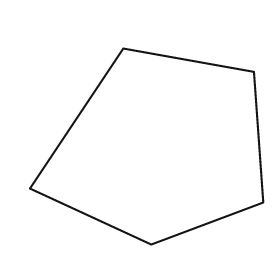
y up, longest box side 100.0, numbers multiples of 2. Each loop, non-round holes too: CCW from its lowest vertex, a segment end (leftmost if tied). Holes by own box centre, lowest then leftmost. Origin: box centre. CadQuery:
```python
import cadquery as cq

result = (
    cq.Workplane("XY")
    .moveTo(2.0, -42.0)
    .lineTo(50.0, -24.0)
    .lineTo(46.0, 32.0)
    .lineTo(-10.0, 42.0)
    .lineTo(-50.0, -18.0)
    .close()
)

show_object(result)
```